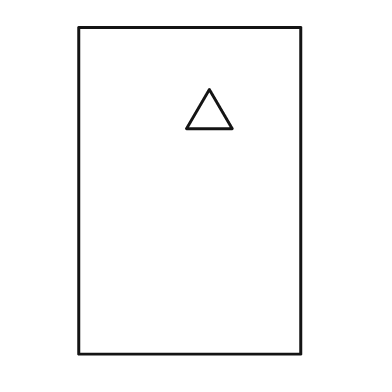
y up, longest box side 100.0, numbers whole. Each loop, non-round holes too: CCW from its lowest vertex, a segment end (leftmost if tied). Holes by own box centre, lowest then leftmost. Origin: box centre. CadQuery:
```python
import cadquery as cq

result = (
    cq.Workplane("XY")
    .moveTo(-34.0, -50.0)
    .lineTo(34.0, -50.0)
    .lineTo(34.0, 50.0)
    .lineTo(-34.0, 50.0)
    .close()
    .moveTo(-1.0, 19.0)
    .lineTo(13.0, 19.0)
    .lineTo(6.0, 31.0)
    .close()
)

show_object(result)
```